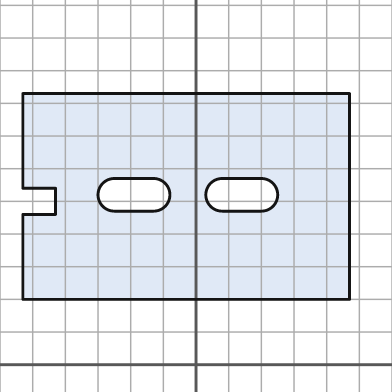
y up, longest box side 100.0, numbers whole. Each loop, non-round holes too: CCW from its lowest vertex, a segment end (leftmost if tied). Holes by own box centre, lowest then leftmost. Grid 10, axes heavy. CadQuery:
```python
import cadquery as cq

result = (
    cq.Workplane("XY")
    .moveTo(-53.0, 20.0)
    .lineTo(47.0, 20.0)
    .lineTo(47.0, 83.0)
    .lineTo(-53.0, 83.0)
    .lineTo(-53.0, 54.0)
    .lineTo(-43.0, 54.0)
    .lineTo(-43.0, 46.0)
    .lineTo(-53.0, 46.0)
    .close()
    .moveTo(-25.0, 47.0)
    .lineTo(-13.0, 47.0)
    .threePointArc((-8.0, 52.0), (-13.0, 57.0))
    .lineTo(-25.0, 57.0)
    .threePointArc((-30.0, 52.0), (-25.0, 47.0))
    .close()
    .moveTo(8.0, 47.0)
    .lineTo(20.0, 47.0)
    .threePointArc((25.0, 52.0), (20.0, 57.0))
    .lineTo(8.0, 57.0)
    .threePointArc((3.0, 52.0), (8.0, 47.0))
    .close()
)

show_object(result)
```